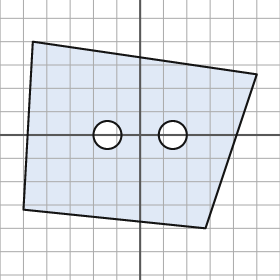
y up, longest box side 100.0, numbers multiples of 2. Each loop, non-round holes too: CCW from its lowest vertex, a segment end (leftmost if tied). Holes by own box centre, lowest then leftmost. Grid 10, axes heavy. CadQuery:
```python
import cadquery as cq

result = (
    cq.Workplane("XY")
    .moveTo(28.0, -40.0)
    .lineTo(50.0, 26.0)
    .lineTo(-46.0, 40.0)
    .lineTo(-50.0, -32.0)
    .close()
    .moveTo(-14.0, 0.0)
    .circle(6.0)
    .moveTo(14.0, 0.0)
    .circle(6.0)
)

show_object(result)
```